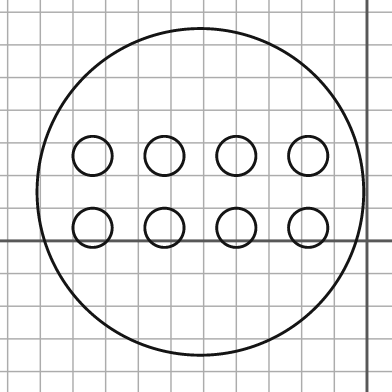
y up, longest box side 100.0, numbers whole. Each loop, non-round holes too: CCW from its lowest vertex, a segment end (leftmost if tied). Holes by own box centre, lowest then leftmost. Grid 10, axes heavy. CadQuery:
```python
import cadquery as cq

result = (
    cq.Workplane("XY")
    .moveTo(-51.0, 15.0)
    .circle(50.0)
    .moveTo(-84.0, 4.0)
    .circle(6.0)
    .moveTo(-62.0, 4.0)
    .circle(6.0)
    .moveTo(-40.0, 4.0)
    .circle(6.0)
    .moveTo(-18.0, 4.0)
    .circle(6.0)
    .moveTo(-84.0, 26.0)
    .circle(6.0)
    .moveTo(-62.0, 26.0)
    .circle(6.0)
    .moveTo(-40.0, 26.0)
    .circle(6.0)
    .moveTo(-18.0, 26.0)
    .circle(6.0)
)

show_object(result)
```